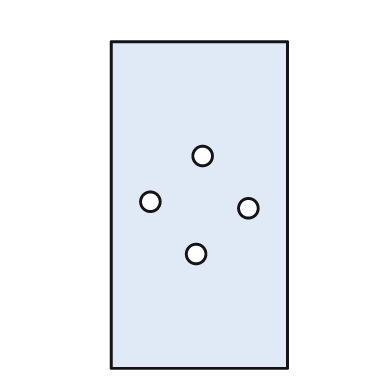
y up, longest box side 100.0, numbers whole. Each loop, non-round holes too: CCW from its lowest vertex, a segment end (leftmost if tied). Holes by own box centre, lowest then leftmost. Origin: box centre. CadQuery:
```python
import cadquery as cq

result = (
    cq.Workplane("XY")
    .moveTo(-27.0, -50.0)
    .lineTo(27.0, -50.0)
    .lineTo(27.0, 50.0)
    .lineTo(-27.0, 50.0)
    .close()
    .moveTo(-1.0, -15.0)
    .circle(3.0)
    .moveTo(15.0, -1.0)
    .circle(3.0)
    .moveTo(-15.0, 1.0)
    .circle(3.0)
    .moveTo(1.0, 15.0)
    .circle(3.0)
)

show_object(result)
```